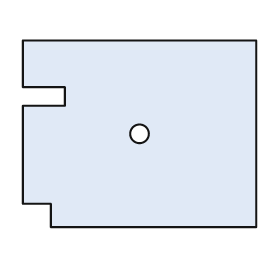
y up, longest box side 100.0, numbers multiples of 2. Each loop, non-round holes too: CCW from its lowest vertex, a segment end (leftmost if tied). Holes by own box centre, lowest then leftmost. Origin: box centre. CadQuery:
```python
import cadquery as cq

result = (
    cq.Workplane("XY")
    .moveTo(-38.0, -40.0)
    .lineTo(50.0, -40.0)
    .lineTo(50.0, 40.0)
    .lineTo(-50.0, 40.0)
    .lineTo(-50.0, 20.0)
    .lineTo(-32.0, 20.0)
    .lineTo(-32.0, 12.0)
    .lineTo(-50.0, 12.0)
    .lineTo(-50.0, -30.0)
    .lineTo(-38.0, -30.0)
    .close()
    .moveTo(0.0, 0.0)
    .circle(4.0)
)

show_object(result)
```